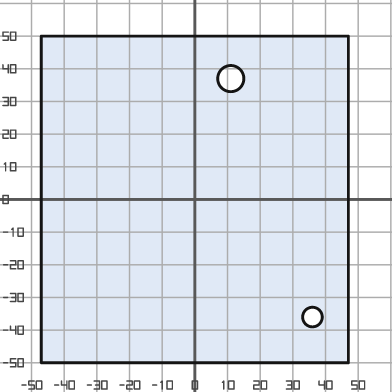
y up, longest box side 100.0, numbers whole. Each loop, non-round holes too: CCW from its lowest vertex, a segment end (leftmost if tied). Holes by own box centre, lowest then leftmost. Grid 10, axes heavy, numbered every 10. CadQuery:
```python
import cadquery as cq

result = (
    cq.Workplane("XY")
    .moveTo(-47.0, -50.0)
    .lineTo(47.0, -50.0)
    .lineTo(47.0, 50.0)
    .lineTo(-47.0, 50.0)
    .close()
    .moveTo(36.0, -36.0)
    .circle(3.0)
    .moveTo(11.0, 37.0)
    .circle(4.0)
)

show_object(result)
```